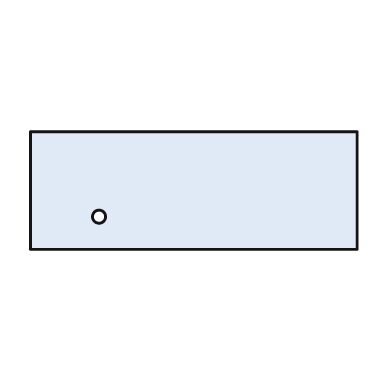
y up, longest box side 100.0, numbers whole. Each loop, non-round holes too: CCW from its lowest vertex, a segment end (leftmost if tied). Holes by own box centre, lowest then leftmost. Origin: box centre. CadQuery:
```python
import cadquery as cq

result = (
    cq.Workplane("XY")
    .moveTo(-50.0, -18.0)
    .lineTo(50.0, -18.0)
    .lineTo(50.0, 18.0)
    .lineTo(-50.0, 18.0)
    .close()
    .moveTo(-29.0, -8.0)
    .circle(2.0)
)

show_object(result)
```